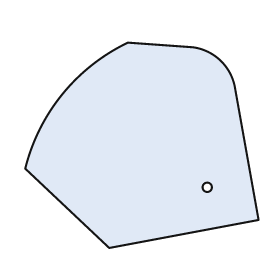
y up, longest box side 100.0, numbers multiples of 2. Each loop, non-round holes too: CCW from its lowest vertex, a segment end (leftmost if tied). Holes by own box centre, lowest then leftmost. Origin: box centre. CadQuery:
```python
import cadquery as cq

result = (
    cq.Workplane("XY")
    .moveTo(-14.0, -44.0)
    .lineTo(50.0, -32.0)
    .lineTo(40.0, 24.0)
    .threePointArc((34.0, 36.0), (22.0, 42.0))
    .lineTo(-6.0, 44.0)
    .threePointArc((-34.0, 22.0), (-50.0, -10.0))
    .close()
    .moveTo(28.0, -18.0)
    .circle(2.0)
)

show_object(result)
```